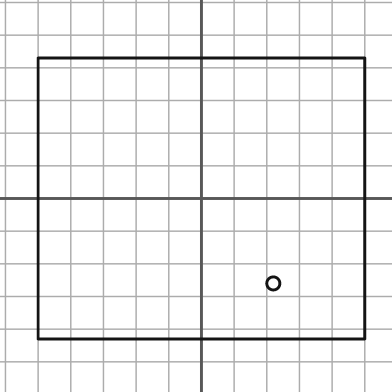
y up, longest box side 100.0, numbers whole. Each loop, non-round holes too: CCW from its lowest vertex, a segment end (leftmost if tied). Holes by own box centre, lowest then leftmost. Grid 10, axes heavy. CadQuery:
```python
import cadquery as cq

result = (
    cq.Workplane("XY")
    .moveTo(-50.0, -43.0)
    .lineTo(50.0, -43.0)
    .lineTo(50.0, 43.0)
    .lineTo(-50.0, 43.0)
    .close()
    .moveTo(22.0, -26.0)
    .circle(2.0)
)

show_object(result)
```